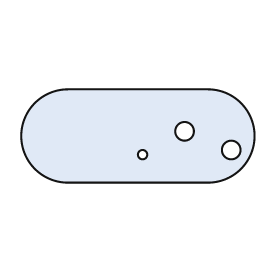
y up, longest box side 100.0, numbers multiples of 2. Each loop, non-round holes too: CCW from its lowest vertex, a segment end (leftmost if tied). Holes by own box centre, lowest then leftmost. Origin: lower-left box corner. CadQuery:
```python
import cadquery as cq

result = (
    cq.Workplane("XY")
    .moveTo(20.0, 0.0)
    .lineTo(80.0, 0.0)
    .threePointArc((100.0, 20.0), (80.0, 40.0))
    .lineTo(20.0, 40.0)
    .threePointArc((0.0, 20.0), (20.0, 0.0))
    .close()
    .moveTo(52.0, 12.0)
    .circle(2.0)
    .moveTo(90.0, 14.0)
    .circle(4.0)
    .moveTo(70.0, 22.0)
    .circle(4.0)
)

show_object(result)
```